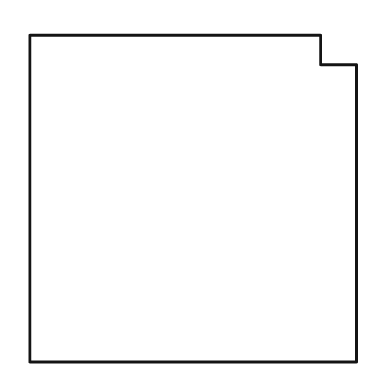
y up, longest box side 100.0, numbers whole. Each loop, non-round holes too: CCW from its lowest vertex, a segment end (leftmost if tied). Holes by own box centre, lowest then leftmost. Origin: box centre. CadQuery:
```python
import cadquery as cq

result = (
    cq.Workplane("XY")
    .moveTo(-50.0, -50.0)
    .lineTo(50.0, -50.0)
    .lineTo(50.0, 41.0)
    .lineTo(39.0, 41.0)
    .lineTo(39.0, 50.0)
    .lineTo(-50.0, 50.0)
    .close()
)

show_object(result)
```